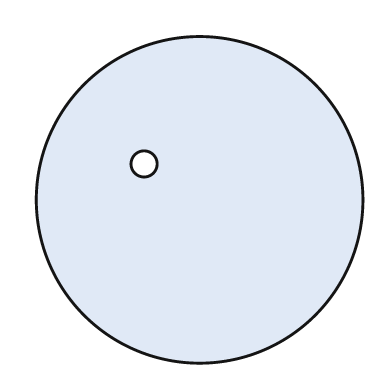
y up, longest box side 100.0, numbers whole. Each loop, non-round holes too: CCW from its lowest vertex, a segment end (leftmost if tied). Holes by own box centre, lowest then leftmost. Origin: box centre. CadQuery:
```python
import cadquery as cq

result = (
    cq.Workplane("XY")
    .moveTo(0.0, 0.0)
    .circle(50.0)
    .moveTo(-17.0, 11.0)
    .circle(4.0)
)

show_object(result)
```